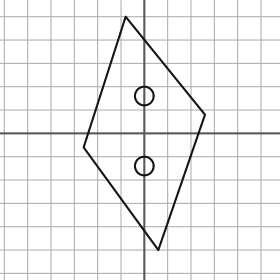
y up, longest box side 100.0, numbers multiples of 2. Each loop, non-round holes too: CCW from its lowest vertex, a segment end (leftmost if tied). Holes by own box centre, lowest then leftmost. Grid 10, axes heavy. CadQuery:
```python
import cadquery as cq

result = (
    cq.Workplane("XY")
    .moveTo(6.0, -50.0)
    .lineTo(26.0, 8.0)
    .lineTo(-8.0, 50.0)
    .lineTo(-26.0, -6.0)
    .close()
    .moveTo(0.0, -14.0)
    .circle(4.0)
    .moveTo(0.0, 16.0)
    .circle(4.0)
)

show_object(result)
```